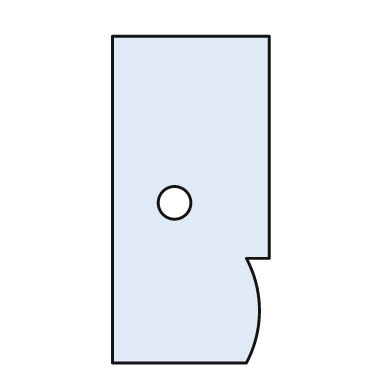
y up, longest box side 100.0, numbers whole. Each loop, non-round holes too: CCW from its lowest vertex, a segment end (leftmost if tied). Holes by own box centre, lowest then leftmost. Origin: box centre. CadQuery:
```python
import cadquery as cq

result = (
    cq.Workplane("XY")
    .moveTo(-24.0, -50.0)
    .lineTo(17.0, -50.0)
    .threePointArc((21.0, -34.0), (17.0, -18.0))
    .lineTo(24.0, -18.0)
    .lineTo(24.0, 50.0)
    .lineTo(-24.0, 50.0)
    .close()
    .moveTo(-5.0, -1.0)
    .circle(5.0)
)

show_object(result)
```